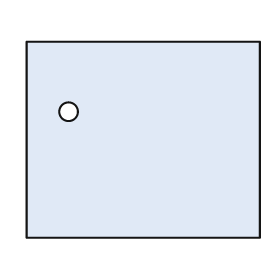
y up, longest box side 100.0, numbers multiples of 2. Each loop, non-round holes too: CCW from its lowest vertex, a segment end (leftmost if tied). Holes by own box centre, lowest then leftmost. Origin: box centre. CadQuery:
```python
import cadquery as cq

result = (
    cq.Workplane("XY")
    .moveTo(-50.0, -42.0)
    .lineTo(50.0, -42.0)
    .lineTo(50.0, 42.0)
    .lineTo(-50.0, 42.0)
    .close()
    .moveTo(-32.0, 12.0)
    .circle(4.0)
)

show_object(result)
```